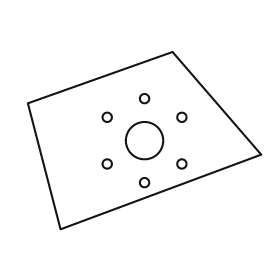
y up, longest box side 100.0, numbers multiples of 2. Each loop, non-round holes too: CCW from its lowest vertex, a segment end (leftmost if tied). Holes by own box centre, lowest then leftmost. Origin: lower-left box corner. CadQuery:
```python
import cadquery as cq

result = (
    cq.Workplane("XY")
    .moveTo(14.0, 0.0)
    .lineTo(100.0, 32.0)
    .lineTo(62.0, 76.0)
    .lineTo(0.0, 54.0)
    .close()
    .moveTo(50.0, 20.0)
    .circle(2.0)
    .moveTo(34.0, 28.0)
    .circle(2.0)
    .moveTo(66.0, 28.0)
    .circle(2.0)
    .moveTo(50.0, 38.0)
    .circle(8.0)
    .moveTo(34.0, 48.0)
    .circle(2.0)
    .moveTo(66.0, 48.0)
    .circle(2.0)
    .moveTo(50.0, 56.0)
    .circle(2.0)
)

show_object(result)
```